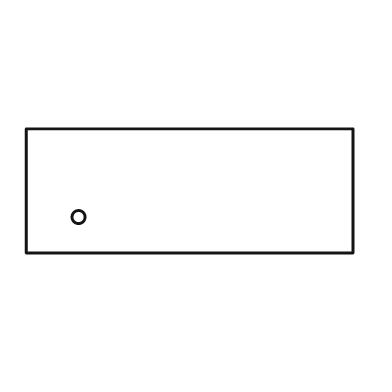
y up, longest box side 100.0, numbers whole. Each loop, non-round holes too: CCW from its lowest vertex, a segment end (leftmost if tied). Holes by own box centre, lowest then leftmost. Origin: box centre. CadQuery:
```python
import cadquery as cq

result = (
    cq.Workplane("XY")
    .moveTo(-50.0, -19.0)
    .lineTo(50.0, -19.0)
    .lineTo(50.0, 19.0)
    .lineTo(-50.0, 19.0)
    .close()
    .moveTo(-34.0, -8.0)
    .circle(2.0)
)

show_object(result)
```